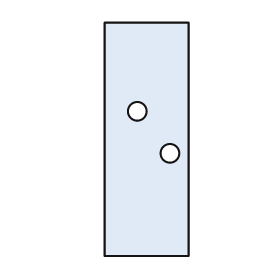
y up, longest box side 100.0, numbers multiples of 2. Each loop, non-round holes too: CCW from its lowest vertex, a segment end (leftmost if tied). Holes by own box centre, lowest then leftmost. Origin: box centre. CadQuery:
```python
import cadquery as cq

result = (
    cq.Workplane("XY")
    .moveTo(-18.0, -50.0)
    .lineTo(18.0, -50.0)
    .lineTo(18.0, 50.0)
    .lineTo(-18.0, 50.0)
    .close()
    .moveTo(10.0, -6.0)
    .circle(4.0)
    .moveTo(-4.0, 12.0)
    .circle(4.0)
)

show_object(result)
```